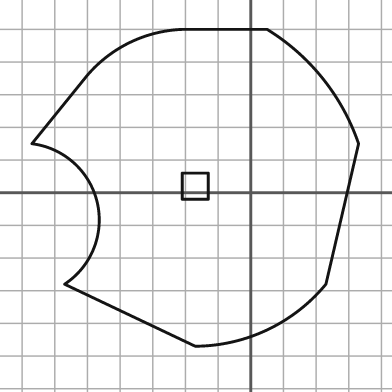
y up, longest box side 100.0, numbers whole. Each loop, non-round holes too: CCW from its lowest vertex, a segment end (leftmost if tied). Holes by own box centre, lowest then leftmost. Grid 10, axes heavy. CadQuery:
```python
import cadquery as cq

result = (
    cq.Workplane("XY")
    .moveTo(-17.0, -47.0)
    .threePointArc((5.0, -42.0), (23.0, -28.0))
    .lineTo(33.0, 15.0)
    .threePointArc((22.0, 35.0), (5.0, 50.0))
    .lineTo(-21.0, 50.0)
    .threePointArc((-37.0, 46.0), (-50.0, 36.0))
    .lineTo(-67.0, 15.0)
    .threePointArc((-47.0, -3.0), (-57.0, -28.0))
    .close()
    .moveTo(-21.0, -2.0)
    .lineTo(-13.0, -2.0)
    .lineTo(-13.0, 6.0)
    .lineTo(-21.0, 6.0)
    .close()
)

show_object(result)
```